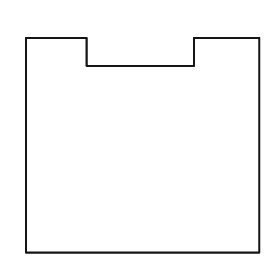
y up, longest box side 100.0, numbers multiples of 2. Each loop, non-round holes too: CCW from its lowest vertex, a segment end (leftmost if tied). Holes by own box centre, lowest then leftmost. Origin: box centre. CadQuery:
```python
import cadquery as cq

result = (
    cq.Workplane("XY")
    .moveTo(-50.0, -46.0)
    .lineTo(50.0, -46.0)
    .lineTo(50.0, 46.0)
    .lineTo(22.0, 46.0)
    .lineTo(22.0, 34.0)
    .lineTo(-24.0, 34.0)
    .lineTo(-24.0, 46.0)
    .lineTo(-50.0, 46.0)
    .close()
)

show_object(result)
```